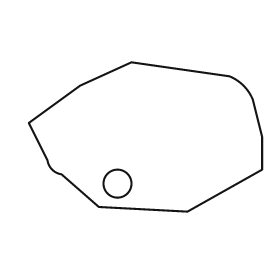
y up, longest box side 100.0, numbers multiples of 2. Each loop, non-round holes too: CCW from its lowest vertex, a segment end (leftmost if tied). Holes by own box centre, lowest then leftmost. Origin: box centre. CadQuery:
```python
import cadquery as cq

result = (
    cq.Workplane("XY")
    .moveTo(18.0, -32.0)
    .lineTo(50.0, -14.0)
    .lineTo(50.0, 0.0)
    .lineTo(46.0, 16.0)
    .threePointArc((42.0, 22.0), (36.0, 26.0))
    .lineTo(-6.0, 32.0)
    .lineTo(-28.0, 22.0)
    .lineTo(-50.0, 6.0)
    .lineTo(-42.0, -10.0)
    .threePointArc((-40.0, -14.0), (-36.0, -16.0))
    .lineTo(-20.0, -30.0)
    .close()
    .moveTo(-12.0, -20.0)
    .circle(6.0)
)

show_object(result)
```